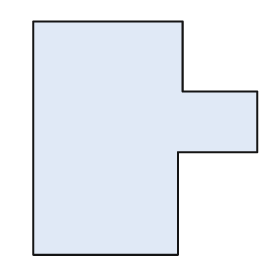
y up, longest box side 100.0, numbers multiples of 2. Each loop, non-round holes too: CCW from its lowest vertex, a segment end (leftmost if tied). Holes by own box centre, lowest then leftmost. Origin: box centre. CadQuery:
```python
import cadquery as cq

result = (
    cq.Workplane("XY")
    .moveTo(-48.0, -50.0)
    .lineTo(14.0, -50.0)
    .lineTo(14.0, -6.0)
    .lineTo(48.0, -6.0)
    .lineTo(48.0, 20.0)
    .lineTo(16.0, 20.0)
    .lineTo(16.0, 50.0)
    .lineTo(-48.0, 50.0)
    .close()
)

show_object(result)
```